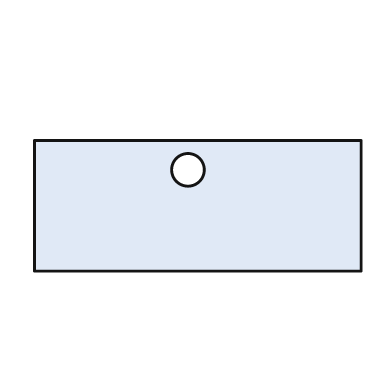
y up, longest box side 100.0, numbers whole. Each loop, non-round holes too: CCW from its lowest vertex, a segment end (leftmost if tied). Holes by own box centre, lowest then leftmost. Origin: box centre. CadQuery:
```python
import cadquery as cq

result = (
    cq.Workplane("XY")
    .moveTo(-50.0, -20.0)
    .lineTo(50.0, -20.0)
    .lineTo(50.0, 20.0)
    .lineTo(-50.0, 20.0)
    .close()
    .moveTo(-3.0, 11.0)
    .circle(5.0)
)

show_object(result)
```